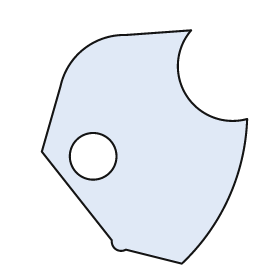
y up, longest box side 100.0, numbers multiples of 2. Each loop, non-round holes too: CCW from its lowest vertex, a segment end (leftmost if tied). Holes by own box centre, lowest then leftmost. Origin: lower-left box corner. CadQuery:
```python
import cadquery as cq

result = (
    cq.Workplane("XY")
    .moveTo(60.0, 0.0)
    .threePointArc((80.0, 28.0), (88.0, 62.0))
    .threePointArc((62.0, 72.0), (64.0, 100.0))
    .lineTo(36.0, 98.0)
    .threePointArc((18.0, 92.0), (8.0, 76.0))
    .lineTo(0.0, 48.0)
    .lineTo(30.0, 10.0)
    .threePointArc((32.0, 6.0), (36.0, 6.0))
    .close()
    .moveTo(22.0, 46.0)
    .circle(10.0)
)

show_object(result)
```